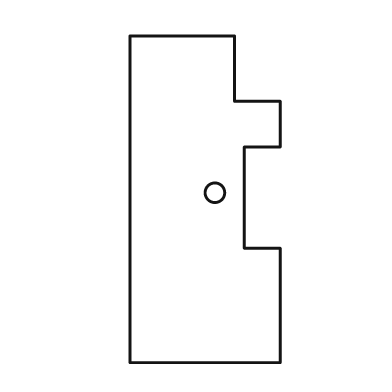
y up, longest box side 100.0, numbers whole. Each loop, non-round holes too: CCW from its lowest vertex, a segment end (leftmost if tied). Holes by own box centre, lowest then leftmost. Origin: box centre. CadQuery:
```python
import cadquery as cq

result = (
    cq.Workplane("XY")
    .moveTo(-23.0, -50.0)
    .lineTo(23.0, -50.0)
    .lineTo(23.0, -15.0)
    .lineTo(12.0, -15.0)
    .lineTo(12.0, 16.0)
    .lineTo(23.0, 16.0)
    .lineTo(23.0, 30.0)
    .lineTo(9.0, 30.0)
    .lineTo(9.0, 50.0)
    .lineTo(-23.0, 50.0)
    .close()
    .moveTo(3.0, 2.0)
    .circle(3.0)
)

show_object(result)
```